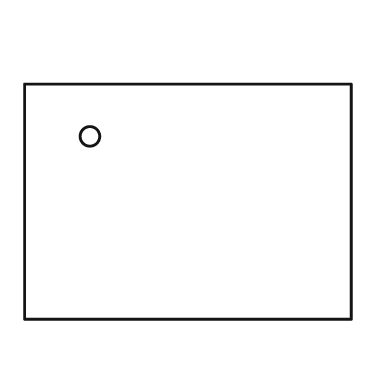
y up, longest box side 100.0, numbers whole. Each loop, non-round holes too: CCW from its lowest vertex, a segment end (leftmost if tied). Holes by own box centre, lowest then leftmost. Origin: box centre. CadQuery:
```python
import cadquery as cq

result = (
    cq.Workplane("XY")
    .moveTo(-50.0, -36.0)
    .lineTo(50.0, -36.0)
    .lineTo(50.0, 36.0)
    .lineTo(-50.0, 36.0)
    .close()
    .moveTo(-30.0, 20.0)
    .circle(3.0)
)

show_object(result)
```